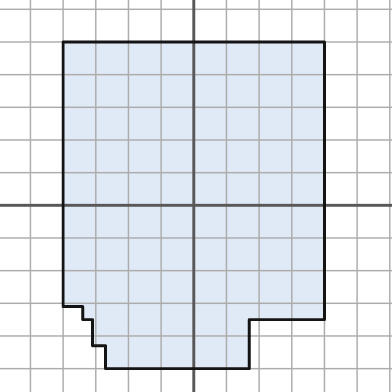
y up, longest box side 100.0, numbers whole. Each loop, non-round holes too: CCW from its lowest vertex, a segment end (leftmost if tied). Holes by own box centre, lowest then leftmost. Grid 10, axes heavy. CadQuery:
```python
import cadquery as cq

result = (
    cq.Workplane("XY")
    .moveTo(-27.0, -50.0)
    .lineTo(17.0, -50.0)
    .lineTo(17.0, -35.0)
    .lineTo(40.0, -35.0)
    .lineTo(40.0, 50.0)
    .lineTo(-40.0, 50.0)
    .lineTo(-40.0, -31.0)
    .lineTo(-34.0, -31.0)
    .lineTo(-34.0, -35.0)
    .lineTo(-31.0, -35.0)
    .lineTo(-31.0, -43.0)
    .lineTo(-27.0, -43.0)
    .close()
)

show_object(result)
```